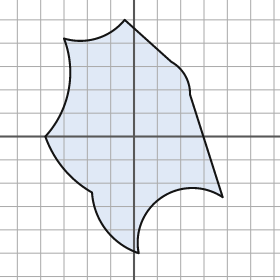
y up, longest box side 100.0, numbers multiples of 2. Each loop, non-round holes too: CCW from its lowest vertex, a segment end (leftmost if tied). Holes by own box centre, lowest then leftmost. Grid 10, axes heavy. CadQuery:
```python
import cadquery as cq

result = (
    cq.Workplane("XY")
    .moveTo(2.0, -50.0)
    .threePointArc((12.0, -26.0), (38.0, -26.0))
    .lineTo(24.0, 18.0)
    .threePointArc((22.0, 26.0), (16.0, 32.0))
    .lineTo(-4.0, 50.0)
    .threePointArc((-16.0, 42.0), (-30.0, 42.0))
    .threePointArc((-28.0, 20.0), (-38.0, 0.0))
    .threePointArc((-30.0, -14.0), (-18.0, -24.0))
    .threePointArc((-12.0, -40.0), (2.0, -50.0))
    .close()
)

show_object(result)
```